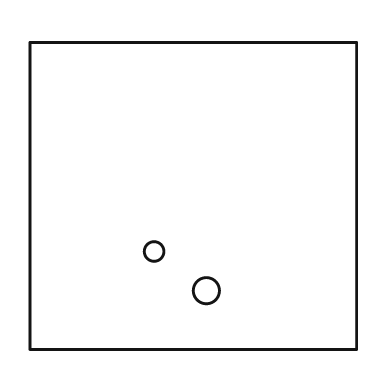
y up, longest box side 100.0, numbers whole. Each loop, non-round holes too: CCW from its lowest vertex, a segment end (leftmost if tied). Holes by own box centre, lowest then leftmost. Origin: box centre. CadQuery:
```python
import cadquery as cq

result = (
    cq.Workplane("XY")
    .moveTo(-50.0, -47.0)
    .lineTo(50.0, -47.0)
    .lineTo(50.0, 47.0)
    .lineTo(-50.0, 47.0)
    .close()
    .moveTo(4.0, -29.0)
    .circle(4.0)
    .moveTo(-12.0, -17.0)
    .circle(3.0)
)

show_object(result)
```